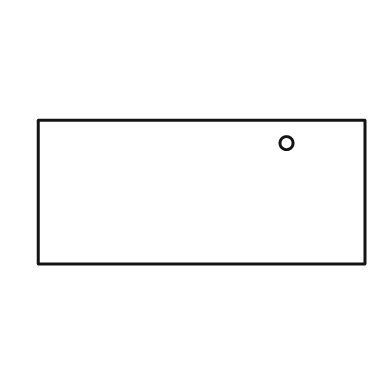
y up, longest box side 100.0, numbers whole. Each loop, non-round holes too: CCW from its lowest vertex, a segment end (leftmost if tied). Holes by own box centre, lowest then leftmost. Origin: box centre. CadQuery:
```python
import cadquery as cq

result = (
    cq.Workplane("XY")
    .moveTo(-50.0, -22.0)
    .lineTo(50.0, -22.0)
    .lineTo(50.0, 22.0)
    .lineTo(-50.0, 22.0)
    .close()
    .moveTo(26.0, 15.0)
    .circle(2.0)
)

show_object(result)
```